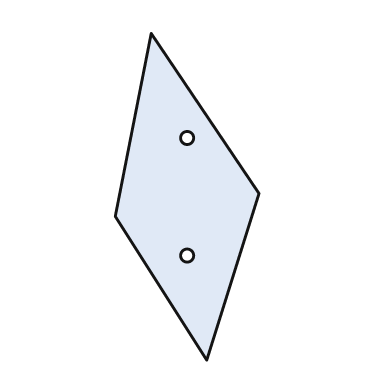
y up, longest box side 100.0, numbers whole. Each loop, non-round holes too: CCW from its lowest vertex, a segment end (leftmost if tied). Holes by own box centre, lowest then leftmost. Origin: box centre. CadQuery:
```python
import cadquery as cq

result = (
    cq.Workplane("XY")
    .moveTo(6.0, -50.0)
    .lineTo(22.0, 1.0)
    .lineTo(-11.0, 50.0)
    .lineTo(-22.0, -6.0)
    .close()
    .moveTo(0.0, -18.0)
    .circle(2.0)
    .moveTo(0.0, 18.0)
    .circle(2.0)
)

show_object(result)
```